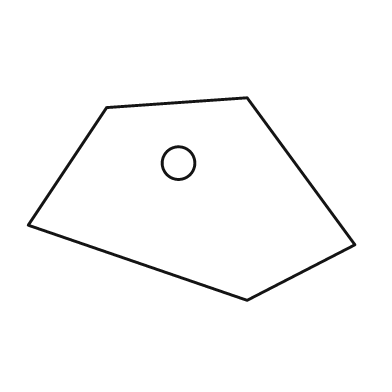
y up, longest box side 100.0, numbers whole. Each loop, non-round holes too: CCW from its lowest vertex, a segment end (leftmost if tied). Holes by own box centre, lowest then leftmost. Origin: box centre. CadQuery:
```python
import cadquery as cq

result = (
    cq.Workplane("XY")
    .moveTo(17.0, -31.0)
    .lineTo(50.0, -14.0)
    .lineTo(17.0, 31.0)
    .lineTo(-26.0, 28.0)
    .lineTo(-50.0, -8.0)
    .close()
    .moveTo(-4.0, 11.0)
    .circle(5.0)
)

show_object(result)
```